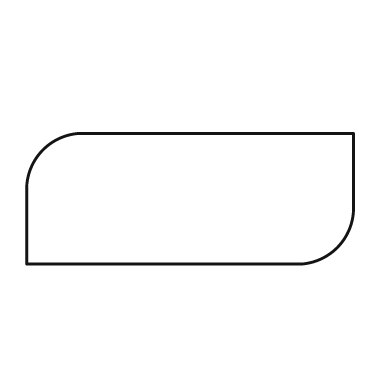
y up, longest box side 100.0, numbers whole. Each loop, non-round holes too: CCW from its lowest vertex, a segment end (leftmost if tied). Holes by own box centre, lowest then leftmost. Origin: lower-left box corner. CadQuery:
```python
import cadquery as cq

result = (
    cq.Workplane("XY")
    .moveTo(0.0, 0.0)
    .lineTo(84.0, 0.0)
    .threePointArc((95.0, 5.0), (100.0, 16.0))
    .lineTo(100.0, 40.0)
    .lineTo(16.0, 40.0)
    .threePointArc((5.0, 35.0), (0.0, 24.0))
    .close()
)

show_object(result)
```